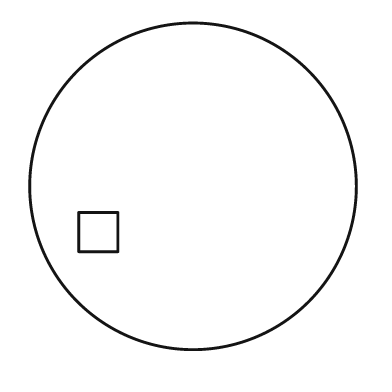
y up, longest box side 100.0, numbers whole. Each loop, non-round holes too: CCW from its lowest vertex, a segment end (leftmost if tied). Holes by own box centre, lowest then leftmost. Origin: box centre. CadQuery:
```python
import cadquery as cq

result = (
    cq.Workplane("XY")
    .moveTo(0.0, 0.0)
    .circle(50.0)
    .moveTo(-35.0, -20.0)
    .lineTo(-23.0, -20.0)
    .lineTo(-23.0, -8.0)
    .lineTo(-35.0, -8.0)
    .close()
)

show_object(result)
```